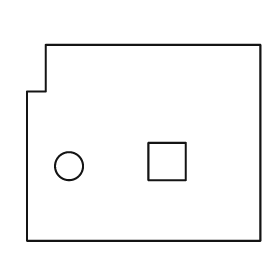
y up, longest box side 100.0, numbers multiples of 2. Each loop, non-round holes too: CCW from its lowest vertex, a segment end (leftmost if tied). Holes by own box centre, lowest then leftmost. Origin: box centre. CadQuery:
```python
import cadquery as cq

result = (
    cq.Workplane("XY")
    .moveTo(-50.0, -42.0)
    .lineTo(50.0, -42.0)
    .lineTo(50.0, 42.0)
    .lineTo(-42.0, 42.0)
    .lineTo(-42.0, 22.0)
    .lineTo(-50.0, 22.0)
    .close()
    .moveTo(-32.0, -10.0)
    .circle(6.0)
    .moveTo(2.0, -16.0)
    .lineTo(18.0, -16.0)
    .lineTo(18.0, 0.0)
    .lineTo(2.0, 0.0)
    .close()
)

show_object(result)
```